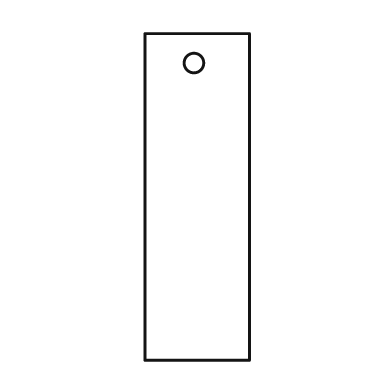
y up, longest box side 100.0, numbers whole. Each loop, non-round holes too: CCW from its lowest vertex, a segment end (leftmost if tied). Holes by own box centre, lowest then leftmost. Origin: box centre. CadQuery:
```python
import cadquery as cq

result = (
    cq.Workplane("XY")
    .moveTo(-16.0, -50.0)
    .lineTo(16.0, -50.0)
    .lineTo(16.0, 50.0)
    .lineTo(-16.0, 50.0)
    .close()
    .moveTo(-1.0, 41.0)
    .circle(3.0)
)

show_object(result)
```